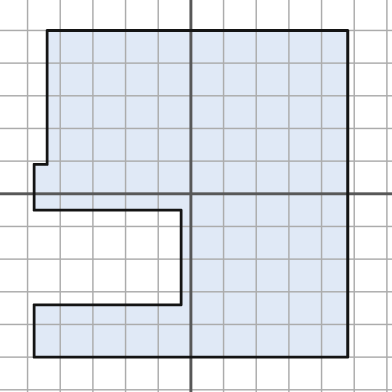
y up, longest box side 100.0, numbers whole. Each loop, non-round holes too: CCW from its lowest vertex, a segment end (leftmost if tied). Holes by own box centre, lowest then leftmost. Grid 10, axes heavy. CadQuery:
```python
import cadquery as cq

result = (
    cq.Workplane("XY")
    .moveTo(-48.0, -50.0)
    .lineTo(48.0, -50.0)
    .lineTo(48.0, 50.0)
    .lineTo(-44.0, 50.0)
    .lineTo(-44.0, 9.0)
    .lineTo(-48.0, 9.0)
    .lineTo(-48.0, -5.0)
    .lineTo(-3.0, -5.0)
    .lineTo(-3.0, -34.0)
    .lineTo(-48.0, -34.0)
    .close()
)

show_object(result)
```